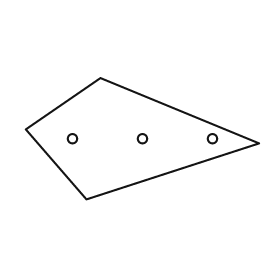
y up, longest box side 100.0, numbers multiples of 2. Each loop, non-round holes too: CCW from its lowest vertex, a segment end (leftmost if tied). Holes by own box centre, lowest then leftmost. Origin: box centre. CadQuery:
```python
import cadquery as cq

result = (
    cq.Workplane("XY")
    .moveTo(-24.0, -26.0)
    .lineTo(50.0, -2.0)
    .lineTo(-18.0, 26.0)
    .lineTo(-50.0, 4.0)
    .close()
    .moveTo(-30.0, 0.0)
    .circle(2.0)
    .moveTo(0.0, 0.0)
    .circle(2.0)
    .moveTo(30.0, 0.0)
    .circle(2.0)
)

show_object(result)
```